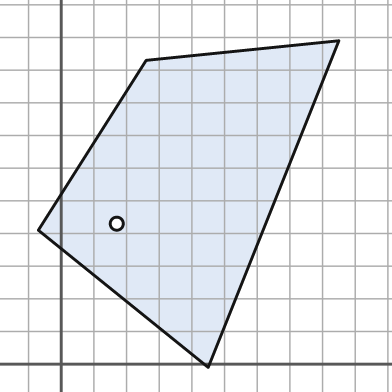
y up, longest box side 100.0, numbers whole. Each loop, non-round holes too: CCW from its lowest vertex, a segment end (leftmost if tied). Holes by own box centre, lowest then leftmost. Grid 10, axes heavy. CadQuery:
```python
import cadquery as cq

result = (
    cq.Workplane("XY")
    .moveTo(45.0, -1.0)
    .lineTo(85.0, 99.0)
    .lineTo(26.0, 93.0)
    .lineTo(-7.0, 41.0)
    .close()
    .moveTo(17.0, 43.0)
    .circle(2.0)
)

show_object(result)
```